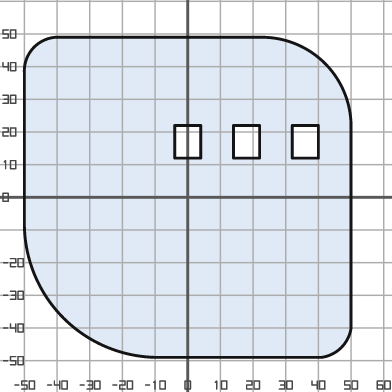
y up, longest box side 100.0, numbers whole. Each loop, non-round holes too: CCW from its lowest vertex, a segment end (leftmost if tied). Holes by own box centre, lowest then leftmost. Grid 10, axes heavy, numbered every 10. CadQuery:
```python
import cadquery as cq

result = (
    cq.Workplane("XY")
    .moveTo(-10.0, -49.0)
    .lineTo(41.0, -49.0)
    .threePointArc((47.0, -46.0), (50.0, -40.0))
    .lineTo(50.0, 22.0)
    .threePointArc((42.0, 41.0), (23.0, 49.0))
    .lineTo(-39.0, 49.0)
    .threePointArc((-47.0, 46.0), (-50.0, 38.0))
    .lineTo(-50.0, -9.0)
    .threePointArc((-38.0, -37.0), (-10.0, -49.0))
    .close()
    .moveTo(-4.0, 12.0)
    .lineTo(4.0, 12.0)
    .lineTo(4.0, 22.0)
    .lineTo(-4.0, 22.0)
    .close()
    .moveTo(14.0, 12.0)
    .lineTo(22.0, 12.0)
    .lineTo(22.0, 22.0)
    .lineTo(14.0, 22.0)
    .close()
    .moveTo(32.0, 12.0)
    .lineTo(40.0, 12.0)
    .lineTo(40.0, 22.0)
    .lineTo(32.0, 22.0)
    .close()
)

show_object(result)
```